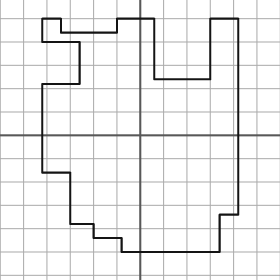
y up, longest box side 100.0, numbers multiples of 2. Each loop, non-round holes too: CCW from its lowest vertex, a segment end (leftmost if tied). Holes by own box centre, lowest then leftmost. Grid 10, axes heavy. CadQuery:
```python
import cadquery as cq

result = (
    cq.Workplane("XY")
    .moveTo(-8.0, -50.0)
    .lineTo(34.0, -50.0)
    .lineTo(34.0, -34.0)
    .lineTo(42.0, -34.0)
    .lineTo(42.0, 50.0)
    .lineTo(30.0, 50.0)
    .lineTo(30.0, 24.0)
    .lineTo(6.0, 24.0)
    .lineTo(6.0, 50.0)
    .lineTo(-10.0, 50.0)
    .lineTo(-10.0, 44.0)
    .lineTo(-34.0, 44.0)
    .lineTo(-34.0, 50.0)
    .lineTo(-42.0, 50.0)
    .lineTo(-42.0, 40.0)
    .lineTo(-26.0, 40.0)
    .lineTo(-26.0, 22.0)
    .lineTo(-42.0, 22.0)
    .lineTo(-42.0, -16.0)
    .lineTo(-30.0, -16.0)
    .lineTo(-30.0, -38.0)
    .lineTo(-20.0, -38.0)
    .lineTo(-20.0, -44.0)
    .lineTo(-8.0, -44.0)
    .close()
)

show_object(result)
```